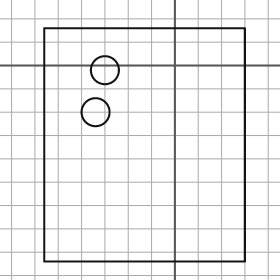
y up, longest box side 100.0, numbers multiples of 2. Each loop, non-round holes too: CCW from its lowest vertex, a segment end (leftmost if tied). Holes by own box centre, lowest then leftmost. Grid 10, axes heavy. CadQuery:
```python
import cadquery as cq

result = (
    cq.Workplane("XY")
    .moveTo(-56.0, -84.0)
    .lineTo(30.0, -84.0)
    .lineTo(30.0, 16.0)
    .lineTo(-56.0, 16.0)
    .close()
    .moveTo(-34.0, -20.0)
    .circle(6.0)
    .moveTo(-30.0, -2.0)
    .circle(6.0)
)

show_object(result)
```